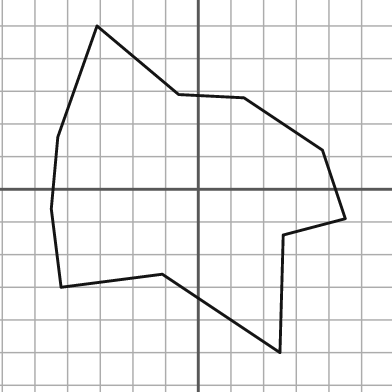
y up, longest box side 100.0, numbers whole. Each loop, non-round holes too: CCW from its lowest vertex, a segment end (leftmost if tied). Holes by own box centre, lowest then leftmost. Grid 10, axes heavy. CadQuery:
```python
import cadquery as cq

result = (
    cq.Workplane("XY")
    .moveTo(25.0, -50.0)
    .lineTo(26.0, -14.0)
    .lineTo(45.0, -9.0)
    .lineTo(38.0, 12.0)
    .lineTo(14.0, 28.0)
    .lineTo(-6.0, 29.0)
    .lineTo(-31.0, 50.0)
    .lineTo(-43.0, 16.0)
    .lineTo(-45.0, -6.0)
    .lineTo(-42.0, -30.0)
    .lineTo(-11.0, -26.0)
    .close()
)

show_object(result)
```